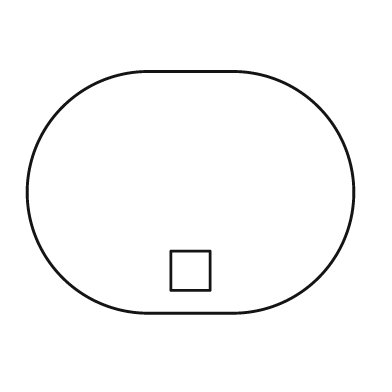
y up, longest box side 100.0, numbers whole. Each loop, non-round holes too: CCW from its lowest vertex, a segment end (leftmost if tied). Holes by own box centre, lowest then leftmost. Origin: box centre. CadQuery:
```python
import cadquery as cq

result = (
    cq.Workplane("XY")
    .moveTo(-13.0, -37.0)
    .lineTo(13.0, -37.0)
    .threePointArc((50.0, 0.0), (13.0, 37.0))
    .lineTo(-13.0, 37.0)
    .threePointArc((-50.0, 0.0), (-13.0, -37.0))
    .close()
    .moveTo(-6.0, -30.0)
    .lineTo(6.0, -30.0)
    .lineTo(6.0, -18.0)
    .lineTo(-6.0, -18.0)
    .close()
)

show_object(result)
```